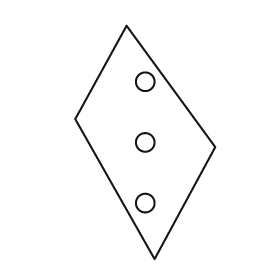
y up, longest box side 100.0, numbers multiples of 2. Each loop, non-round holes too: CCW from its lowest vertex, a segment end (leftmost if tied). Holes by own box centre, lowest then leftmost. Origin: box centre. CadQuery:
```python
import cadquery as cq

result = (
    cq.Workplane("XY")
    .moveTo(4.0, -50.0)
    .lineTo(30.0, -2.0)
    .lineTo(-8.0, 50.0)
    .lineTo(-30.0, 10.0)
    .close()
    .moveTo(0.0, -26.0)
    .circle(4.0)
    .moveTo(0.0, 0.0)
    .circle(4.0)
    .moveTo(0.0, 26.0)
    .circle(4.0)
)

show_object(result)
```